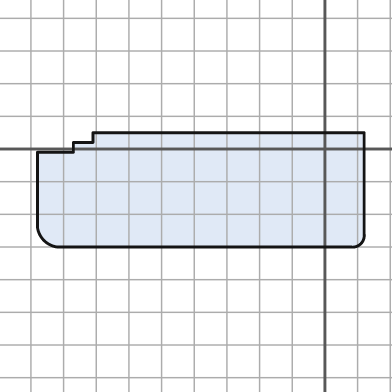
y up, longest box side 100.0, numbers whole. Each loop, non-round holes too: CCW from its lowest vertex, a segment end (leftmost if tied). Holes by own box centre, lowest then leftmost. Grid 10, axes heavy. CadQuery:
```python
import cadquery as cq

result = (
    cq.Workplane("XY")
    .moveTo(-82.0, -30.0)
    .lineTo(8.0, -30.0)
    .threePointArc((11.0, -29.0), (12.0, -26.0))
    .lineTo(12.0, 5.0)
    .lineTo(-71.0, 5.0)
    .lineTo(-71.0, 2.0)
    .lineTo(-77.0, 2.0)
    .lineTo(-77.0, -1.0)
    .lineTo(-88.0, -1.0)
    .lineTo(-88.0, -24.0)
    .threePointArc((-86.0, -28.0), (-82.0, -30.0))
    .close()
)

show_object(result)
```